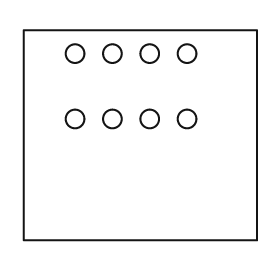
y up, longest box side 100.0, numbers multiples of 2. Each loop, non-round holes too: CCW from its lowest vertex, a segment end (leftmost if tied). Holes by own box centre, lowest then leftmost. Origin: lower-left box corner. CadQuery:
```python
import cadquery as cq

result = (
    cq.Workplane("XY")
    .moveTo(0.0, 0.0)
    .lineTo(100.0, 0.0)
    .lineTo(100.0, 90.0)
    .lineTo(0.0, 90.0)
    .close()
    .moveTo(22.0, 52.0)
    .circle(4.0)
    .moveTo(38.0, 52.0)
    .circle(4.0)
    .moveTo(54.0, 52.0)
    .circle(4.0)
    .moveTo(70.0, 52.0)
    .circle(4.0)
    .moveTo(22.0, 80.0)
    .circle(4.0)
    .moveTo(38.0, 80.0)
    .circle(4.0)
    .moveTo(54.0, 80.0)
    .circle(4.0)
    .moveTo(70.0, 80.0)
    .circle(4.0)
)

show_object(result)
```